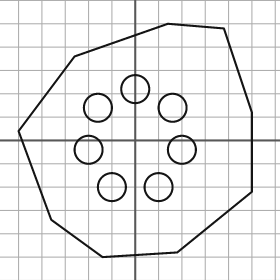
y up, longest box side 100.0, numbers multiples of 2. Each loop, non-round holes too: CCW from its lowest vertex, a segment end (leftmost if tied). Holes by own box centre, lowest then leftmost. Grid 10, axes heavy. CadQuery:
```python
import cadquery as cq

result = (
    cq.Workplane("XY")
    .moveTo(-14.0, -50.0)
    .lineTo(18.0, -48.0)
    .lineTo(50.0, -22.0)
    .lineTo(50.0, 12.0)
    .lineTo(38.0, 48.0)
    .lineTo(14.0, 50.0)
    .lineTo(-26.0, 36.0)
    .lineTo(-50.0, 4.0)
    .lineTo(-36.0, -34.0)
    .close()
    .moveTo(-10.0, -20.0)
    .circle(6.0)
    .moveTo(10.0, -20.0)
    .circle(6.0)
    .moveTo(-20.0, -4.0)
    .circle(6.0)
    .moveTo(20.0, -4.0)
    .circle(6.0)
    .moveTo(-16.0, 14.0)
    .circle(6.0)
    .moveTo(16.0, 14.0)
    .circle(6.0)
    .moveTo(0.0, 22.0)
    .circle(6.0)
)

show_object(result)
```